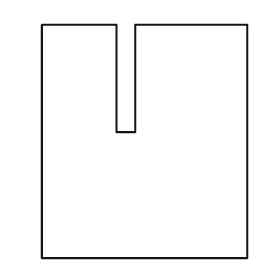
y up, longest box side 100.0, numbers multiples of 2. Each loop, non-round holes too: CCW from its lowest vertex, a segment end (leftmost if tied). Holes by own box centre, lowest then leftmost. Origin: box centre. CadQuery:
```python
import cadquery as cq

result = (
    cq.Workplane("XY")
    .moveTo(-44.0, -50.0)
    .lineTo(44.0, -50.0)
    .lineTo(44.0, 50.0)
    .lineTo(-4.0, 50.0)
    .lineTo(-4.0, 4.0)
    .lineTo(-12.0, 4.0)
    .lineTo(-12.0, 50.0)
    .lineTo(-44.0, 50.0)
    .close()
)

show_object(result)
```